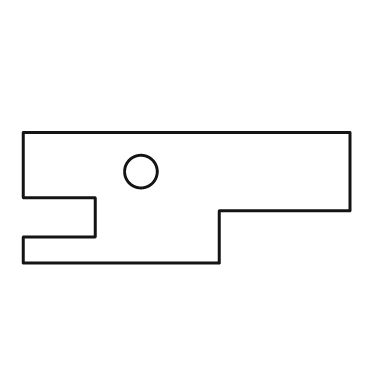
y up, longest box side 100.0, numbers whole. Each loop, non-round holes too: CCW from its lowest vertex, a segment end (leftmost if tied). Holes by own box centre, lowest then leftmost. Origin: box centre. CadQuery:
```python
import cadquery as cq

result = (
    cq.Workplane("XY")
    .moveTo(-50.0, -20.0)
    .lineTo(10.0, -20.0)
    .lineTo(10.0, -4.0)
    .lineTo(50.0, -4.0)
    .lineTo(50.0, 20.0)
    .lineTo(-50.0, 20.0)
    .lineTo(-50.0, 0.0)
    .lineTo(-28.0, 0.0)
    .lineTo(-28.0, -12.0)
    .lineTo(-50.0, -12.0)
    .close()
    .moveTo(-14.0, 8.0)
    .circle(5.0)
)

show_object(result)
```